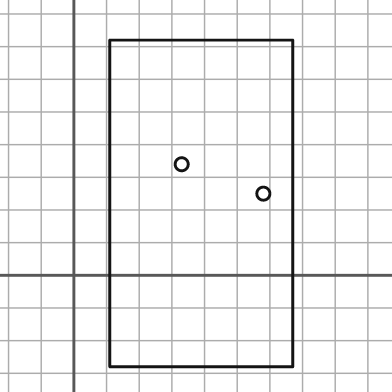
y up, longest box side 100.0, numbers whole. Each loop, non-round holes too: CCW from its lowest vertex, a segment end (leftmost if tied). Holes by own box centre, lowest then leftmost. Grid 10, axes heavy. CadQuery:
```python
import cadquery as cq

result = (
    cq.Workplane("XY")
    .moveTo(11.0, -28.0)
    .lineTo(67.0, -28.0)
    .lineTo(67.0, 72.0)
    .lineTo(11.0, 72.0)
    .close()
    .moveTo(58.0, 25.0)
    .circle(2.0)
    .moveTo(33.0, 34.0)
    .circle(2.0)
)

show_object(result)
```